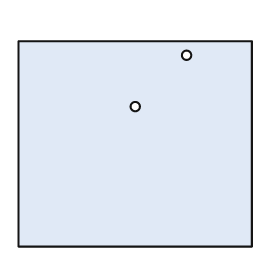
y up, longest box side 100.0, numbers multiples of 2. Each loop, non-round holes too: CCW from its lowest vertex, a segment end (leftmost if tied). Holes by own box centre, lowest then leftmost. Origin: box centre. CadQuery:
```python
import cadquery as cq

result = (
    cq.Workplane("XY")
    .moveTo(-50.0, -44.0)
    .lineTo(50.0, -44.0)
    .lineTo(50.0, 44.0)
    .lineTo(-50.0, 44.0)
    .close()
    .moveTo(0.0, 16.0)
    .circle(2.0)
    .moveTo(22.0, 38.0)
    .circle(2.0)
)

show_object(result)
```